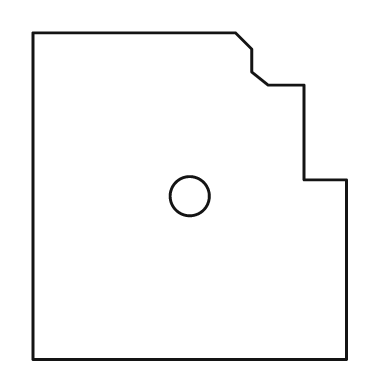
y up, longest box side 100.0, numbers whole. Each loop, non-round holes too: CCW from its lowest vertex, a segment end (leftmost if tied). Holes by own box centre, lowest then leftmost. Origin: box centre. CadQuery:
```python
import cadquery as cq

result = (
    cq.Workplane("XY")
    .moveTo(-48.0, -50.0)
    .lineTo(48.0, -50.0)
    .lineTo(48.0, 5.0)
    .lineTo(35.0, 5.0)
    .lineTo(35.0, 34.0)
    .lineTo(24.0, 34.0)
    .lineTo(19.0, 38.0)
    .lineTo(19.0, 45.0)
    .lineTo(14.0, 50.0)
    .lineTo(-48.0, 50.0)
    .close()
    .moveTo(0.0, 0.0)
    .circle(6.0)
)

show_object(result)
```